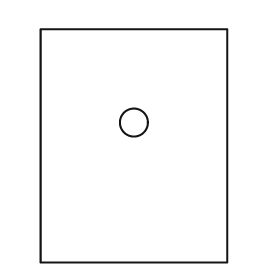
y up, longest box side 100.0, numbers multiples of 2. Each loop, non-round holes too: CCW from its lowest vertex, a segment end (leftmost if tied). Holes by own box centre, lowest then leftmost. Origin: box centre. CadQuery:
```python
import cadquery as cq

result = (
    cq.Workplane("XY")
    .moveTo(-40.0, -50.0)
    .lineTo(40.0, -50.0)
    .lineTo(40.0, 50.0)
    .lineTo(-40.0, 50.0)
    .close()
    .moveTo(0.0, 10.0)
    .circle(6.0)
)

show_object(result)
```